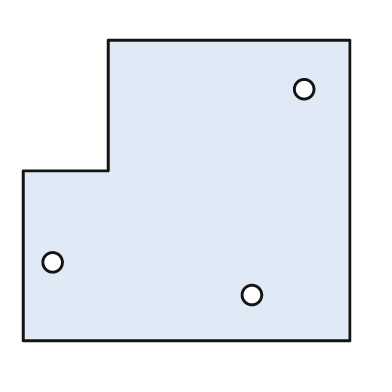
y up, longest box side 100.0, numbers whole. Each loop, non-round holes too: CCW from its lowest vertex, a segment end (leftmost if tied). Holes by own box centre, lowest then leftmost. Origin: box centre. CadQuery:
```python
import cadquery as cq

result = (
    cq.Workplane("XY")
    .moveTo(-50.0, -46.0)
    .lineTo(50.0, -46.0)
    .lineTo(50.0, 46.0)
    .lineTo(-24.0, 46.0)
    .lineTo(-24.0, 6.0)
    .lineTo(-50.0, 6.0)
    .close()
    .moveTo(20.0, -32.0)
    .circle(3.0)
    .moveTo(-41.0, -22.0)
    .circle(3.0)
    .moveTo(36.0, 31.0)
    .circle(3.0)
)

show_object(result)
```